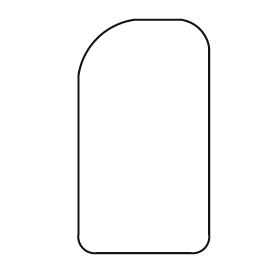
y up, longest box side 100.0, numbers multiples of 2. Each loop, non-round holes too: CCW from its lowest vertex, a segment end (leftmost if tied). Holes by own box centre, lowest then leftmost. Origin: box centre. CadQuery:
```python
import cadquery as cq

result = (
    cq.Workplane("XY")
    .moveTo(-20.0, -50.0)
    .lineTo(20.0, -50.0)
    .threePointArc((26.0, -48.0), (28.0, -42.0))
    .lineTo(28.0, 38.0)
    .threePointArc((24.0, 46.0), (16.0, 50.0))
    .lineTo(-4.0, 50.0)
    .threePointArc((-20.0, 42.0), (-28.0, 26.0))
    .lineTo(-28.0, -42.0)
    .threePointArc((-26.0, -48.0), (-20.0, -50.0))
    .close()
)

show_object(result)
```